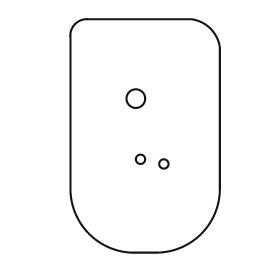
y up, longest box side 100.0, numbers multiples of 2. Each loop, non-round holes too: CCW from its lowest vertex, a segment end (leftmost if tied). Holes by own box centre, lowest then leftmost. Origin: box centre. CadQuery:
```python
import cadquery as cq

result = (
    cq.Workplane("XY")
    .moveTo(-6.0, -50.0)
    .lineTo(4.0, -50.0)
    .threePointArc((24.0, -42.0), (32.0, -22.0))
    .lineTo(32.0, 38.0)
    .threePointArc((28.0, 46.0), (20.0, 50.0))
    .lineTo(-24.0, 50.0)
    .threePointArc((-30.0, 48.0), (-32.0, 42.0))
    .lineTo(-32.0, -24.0)
    .threePointArc((-24.0, -42.0), (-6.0, -50.0))
    .close()
    .moveTo(8.0, -12.0)
    .circle(2.0)
    .moveTo(-2.0, -10.0)
    .circle(2.0)
    .moveTo(-4.0, 16.0)
    .circle(4.0)
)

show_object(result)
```